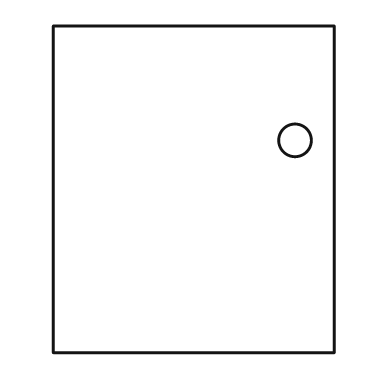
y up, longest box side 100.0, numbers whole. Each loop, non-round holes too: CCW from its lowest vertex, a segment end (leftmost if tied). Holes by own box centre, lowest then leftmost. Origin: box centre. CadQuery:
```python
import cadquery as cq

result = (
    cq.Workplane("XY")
    .moveTo(-43.0, -50.0)
    .lineTo(43.0, -50.0)
    .lineTo(43.0, 50.0)
    .lineTo(-43.0, 50.0)
    .close()
    .moveTo(31.0, 15.0)
    .circle(5.0)
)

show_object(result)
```